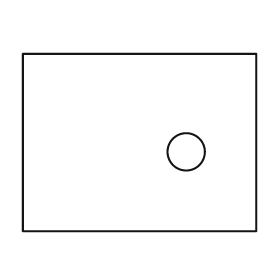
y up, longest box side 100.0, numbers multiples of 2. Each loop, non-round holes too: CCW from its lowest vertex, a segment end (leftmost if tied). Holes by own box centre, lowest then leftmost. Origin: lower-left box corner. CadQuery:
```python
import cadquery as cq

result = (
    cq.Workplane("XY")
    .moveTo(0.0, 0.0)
    .lineTo(100.0, 0.0)
    .lineTo(100.0, 76.0)
    .lineTo(0.0, 76.0)
    .close()
    .moveTo(70.0, 34.0)
    .circle(8.0)
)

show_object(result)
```